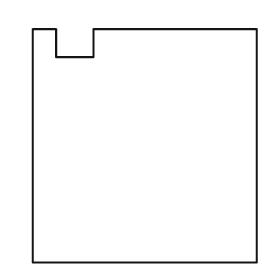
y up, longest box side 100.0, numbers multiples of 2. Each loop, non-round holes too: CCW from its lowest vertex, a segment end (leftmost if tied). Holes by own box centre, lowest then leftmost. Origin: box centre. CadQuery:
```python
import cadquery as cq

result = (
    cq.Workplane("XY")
    .moveTo(-48.0, -50.0)
    .lineTo(48.0, -50.0)
    .lineTo(48.0, 50.0)
    .lineTo(-22.0, 50.0)
    .lineTo(-22.0, 38.0)
    .lineTo(-38.0, 38.0)
    .lineTo(-38.0, 50.0)
    .lineTo(-48.0, 50.0)
    .close()
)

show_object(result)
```